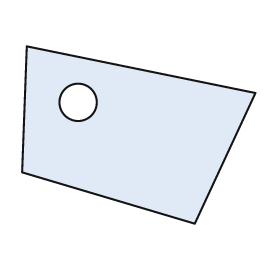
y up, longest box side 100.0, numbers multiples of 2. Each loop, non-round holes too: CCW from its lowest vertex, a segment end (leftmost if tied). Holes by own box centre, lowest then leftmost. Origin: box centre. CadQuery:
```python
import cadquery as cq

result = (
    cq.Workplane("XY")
    .moveTo(24.0, -38.0)
    .lineTo(50.0, 18.0)
    .lineTo(-48.0, 38.0)
    .lineTo(-50.0, -16.0)
    .close()
    .moveTo(-26.0, 14.0)
    .circle(8.0)
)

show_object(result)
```